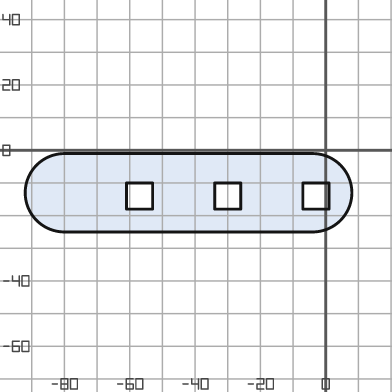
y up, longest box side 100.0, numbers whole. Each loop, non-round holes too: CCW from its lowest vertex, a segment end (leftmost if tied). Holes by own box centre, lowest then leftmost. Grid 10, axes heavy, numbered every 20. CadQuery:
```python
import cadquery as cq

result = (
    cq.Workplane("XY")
    .moveTo(-80.0, -25.0)
    .lineTo(-4.0, -25.0)
    .threePointArc((8.0, -13.0), (-4.0, -1.0))
    .lineTo(-80.0, -1.0)
    .threePointArc((-92.0, -13.0), (-80.0, -25.0))
    .close()
    .moveTo(-61.0, -18.0)
    .lineTo(-53.0, -18.0)
    .lineTo(-53.0, -10.0)
    .lineTo(-61.0, -10.0)
    .close()
    .moveTo(-34.0, -18.0)
    .lineTo(-26.0, -18.0)
    .lineTo(-26.0, -10.0)
    .lineTo(-34.0, -10.0)
    .close()
    .moveTo(-7.0, -18.0)
    .lineTo(1.0, -18.0)
    .lineTo(1.0, -10.0)
    .lineTo(-7.0, -10.0)
    .close()
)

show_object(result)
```